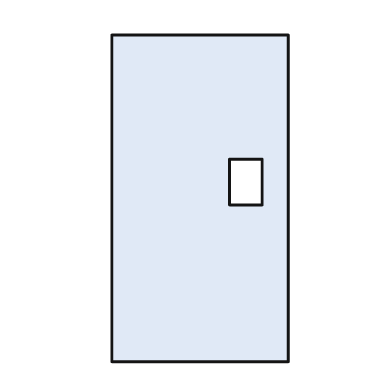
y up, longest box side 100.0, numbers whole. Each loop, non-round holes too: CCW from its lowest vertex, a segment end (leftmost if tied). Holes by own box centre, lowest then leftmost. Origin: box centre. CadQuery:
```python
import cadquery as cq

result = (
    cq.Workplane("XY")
    .moveTo(-27.0, -50.0)
    .lineTo(27.0, -50.0)
    .lineTo(27.0, 50.0)
    .lineTo(-27.0, 50.0)
    .close()
    .moveTo(9.0, -2.0)
    .lineTo(19.0, -2.0)
    .lineTo(19.0, 12.0)
    .lineTo(9.0, 12.0)
    .close()
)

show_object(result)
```